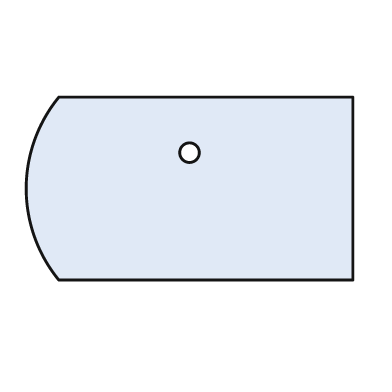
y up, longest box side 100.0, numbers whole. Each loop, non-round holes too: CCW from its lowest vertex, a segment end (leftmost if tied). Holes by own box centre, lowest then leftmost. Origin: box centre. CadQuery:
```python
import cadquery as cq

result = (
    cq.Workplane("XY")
    .moveTo(-40.0, -28.0)
    .lineTo(50.0, -28.0)
    .lineTo(50.0, 28.0)
    .lineTo(-40.0, 28.0)
    .threePointArc((-50.0, 0.0), (-40.0, -28.0))
    .close()
    .moveTo(0.0, 11.0)
    .circle(3.0)
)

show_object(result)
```